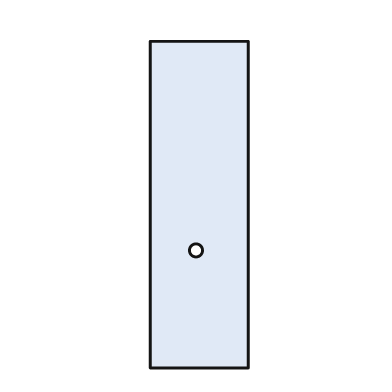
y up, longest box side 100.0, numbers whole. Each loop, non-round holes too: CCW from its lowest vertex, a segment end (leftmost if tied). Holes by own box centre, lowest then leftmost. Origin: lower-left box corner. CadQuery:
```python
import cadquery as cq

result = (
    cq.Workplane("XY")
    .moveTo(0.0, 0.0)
    .lineTo(30.0, 0.0)
    .lineTo(30.0, 100.0)
    .lineTo(0.0, 100.0)
    .close()
    .moveTo(14.0, 36.0)
    .circle(2.0)
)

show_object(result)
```